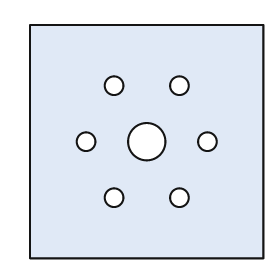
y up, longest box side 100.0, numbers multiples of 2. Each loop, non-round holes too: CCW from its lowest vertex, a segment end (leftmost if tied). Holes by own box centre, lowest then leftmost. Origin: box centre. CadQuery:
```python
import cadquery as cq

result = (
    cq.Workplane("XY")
    .moveTo(-50.0, -50.0)
    .lineTo(50.0, -50.0)
    .lineTo(50.0, 50.0)
    .lineTo(-50.0, 50.0)
    .close()
    .moveTo(-14.0, -24.0)
    .circle(4.0)
    .moveTo(14.0, -24.0)
    .circle(4.0)
    .moveTo(-26.0, 0.0)
    .circle(4.0)
    .moveTo(0.0, 0.0)
    .circle(8.0)
    .moveTo(26.0, 0.0)
    .circle(4.0)
    .moveTo(-14.0, 24.0)
    .circle(4.0)
    .moveTo(14.0, 24.0)
    .circle(4.0)
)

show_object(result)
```